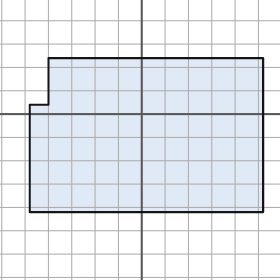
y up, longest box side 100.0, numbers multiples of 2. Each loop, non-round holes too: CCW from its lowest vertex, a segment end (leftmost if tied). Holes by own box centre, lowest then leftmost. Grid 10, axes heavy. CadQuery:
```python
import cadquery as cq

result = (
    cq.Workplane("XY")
    .moveTo(-48.0, -42.0)
    .lineTo(52.0, -42.0)
    .lineTo(52.0, 24.0)
    .lineTo(-40.0, 24.0)
    .lineTo(-40.0, 4.0)
    .lineTo(-48.0, 4.0)
    .close()
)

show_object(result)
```